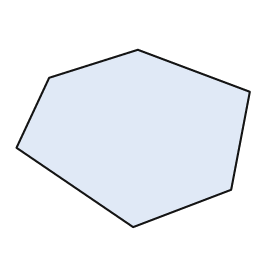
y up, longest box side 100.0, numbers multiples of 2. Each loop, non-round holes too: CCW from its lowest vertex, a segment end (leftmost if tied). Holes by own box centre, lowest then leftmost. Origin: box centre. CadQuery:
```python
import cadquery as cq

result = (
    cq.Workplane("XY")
    .moveTo(0.0, -38.0)
    .lineTo(42.0, -22.0)
    .lineTo(50.0, 20.0)
    .lineTo(2.0, 38.0)
    .lineTo(-36.0, 26.0)
    .lineTo(-50.0, -4.0)
    .close()
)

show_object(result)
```